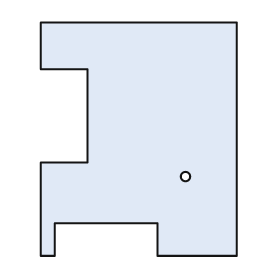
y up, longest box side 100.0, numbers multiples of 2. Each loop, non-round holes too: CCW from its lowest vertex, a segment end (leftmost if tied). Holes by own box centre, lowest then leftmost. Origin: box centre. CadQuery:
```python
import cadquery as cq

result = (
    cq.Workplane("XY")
    .moveTo(-42.0, -50.0)
    .lineTo(-36.0, -50.0)
    .lineTo(-36.0, -36.0)
    .lineTo(8.0, -36.0)
    .lineTo(8.0, -50.0)
    .lineTo(42.0, -50.0)
    .lineTo(42.0, 50.0)
    .lineTo(-42.0, 50.0)
    .lineTo(-42.0, 30.0)
    .lineTo(-22.0, 30.0)
    .lineTo(-22.0, -10.0)
    .lineTo(-42.0, -10.0)
    .close()
    .moveTo(20.0, -16.0)
    .circle(2.0)
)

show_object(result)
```